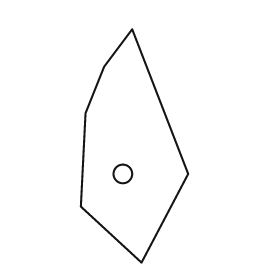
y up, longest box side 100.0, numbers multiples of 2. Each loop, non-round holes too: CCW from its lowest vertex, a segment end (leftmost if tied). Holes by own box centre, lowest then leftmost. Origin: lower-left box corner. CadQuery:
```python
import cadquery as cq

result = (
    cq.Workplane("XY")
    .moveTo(26.0, 0.0)
    .lineTo(46.0, 38.0)
    .lineTo(22.0, 100.0)
    .lineTo(10.0, 84.0)
    .lineTo(2.0, 64.0)
    .lineTo(0.0, 24.0)
    .close()
    .moveTo(18.0, 38.0)
    .circle(4.0)
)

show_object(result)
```